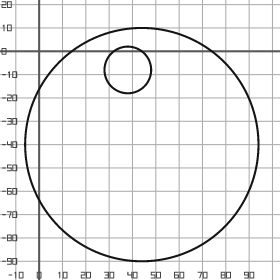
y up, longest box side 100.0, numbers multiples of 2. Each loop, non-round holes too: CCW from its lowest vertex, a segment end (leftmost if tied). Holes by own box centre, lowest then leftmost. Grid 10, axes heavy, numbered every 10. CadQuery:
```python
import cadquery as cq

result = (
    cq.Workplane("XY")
    .moveTo(44.0, -40.0)
    .circle(50.0)
    .moveTo(38.0, -8.0)
    .circle(10.0)
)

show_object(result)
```